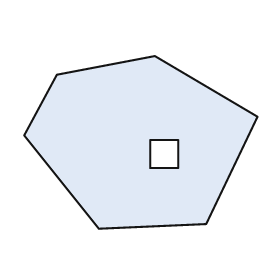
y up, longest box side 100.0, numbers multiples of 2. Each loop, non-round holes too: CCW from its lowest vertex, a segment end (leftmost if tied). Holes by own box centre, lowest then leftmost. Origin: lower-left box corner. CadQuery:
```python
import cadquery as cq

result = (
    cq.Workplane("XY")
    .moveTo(32.0, 0.0)
    .lineTo(78.0, 2.0)
    .lineTo(100.0, 48.0)
    .lineTo(56.0, 74.0)
    .lineTo(14.0, 66.0)
    .lineTo(0.0, 40.0)
    .close()
    .moveTo(54.0, 26.0)
    .lineTo(66.0, 26.0)
    .lineTo(66.0, 38.0)
    .lineTo(54.0, 38.0)
    .close()
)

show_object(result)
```